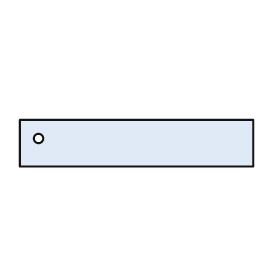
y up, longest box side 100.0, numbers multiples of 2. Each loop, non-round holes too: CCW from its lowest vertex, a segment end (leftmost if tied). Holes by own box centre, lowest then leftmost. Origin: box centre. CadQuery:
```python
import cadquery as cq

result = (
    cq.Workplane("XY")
    .moveTo(-50.0, -10.0)
    .lineTo(50.0, -10.0)
    .lineTo(50.0, 10.0)
    .lineTo(-50.0, 10.0)
    .close()
    .moveTo(-42.0, 2.0)
    .circle(2.0)
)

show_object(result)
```